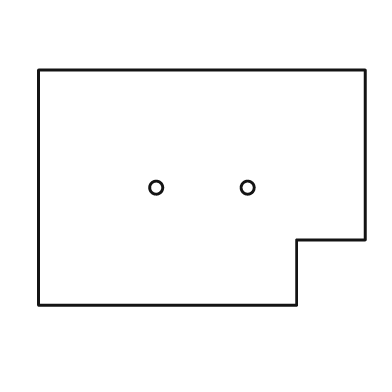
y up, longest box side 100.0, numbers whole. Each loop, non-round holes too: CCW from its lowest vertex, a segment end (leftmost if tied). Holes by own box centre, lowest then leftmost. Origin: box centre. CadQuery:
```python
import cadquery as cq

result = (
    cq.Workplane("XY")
    .moveTo(-50.0, -36.0)
    .lineTo(29.0, -36.0)
    .lineTo(29.0, -16.0)
    .lineTo(50.0, -16.0)
    .lineTo(50.0, 36.0)
    .lineTo(-50.0, 36.0)
    .close()
    .moveTo(-14.0, 0.0)
    .circle(2.0)
    .moveTo(14.0, 0.0)
    .circle(2.0)
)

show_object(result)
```